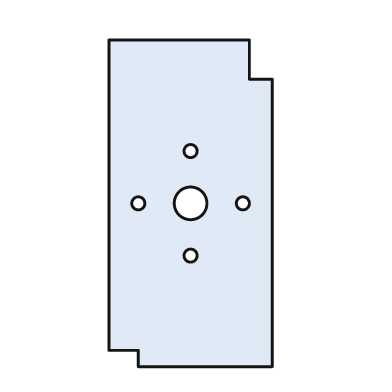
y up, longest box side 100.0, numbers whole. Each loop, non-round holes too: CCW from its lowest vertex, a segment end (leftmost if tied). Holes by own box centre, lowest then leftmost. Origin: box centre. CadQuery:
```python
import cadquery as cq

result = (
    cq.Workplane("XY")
    .moveTo(-16.0, -50.0)
    .lineTo(25.0, -50.0)
    .lineTo(25.0, 38.0)
    .lineTo(18.0, 38.0)
    .lineTo(18.0, 50.0)
    .lineTo(-25.0, 50.0)
    .lineTo(-25.0, -45.0)
    .lineTo(-16.0, -45.0)
    .close()
    .moveTo(0.0, -16.0)
    .circle(2.0)
    .moveTo(-16.0, 0.0)
    .circle(2.0)
    .moveTo(0.0, 0.0)
    .circle(5.0)
    .moveTo(16.0, 0.0)
    .circle(2.0)
    .moveTo(0.0, 16.0)
    .circle(2.0)
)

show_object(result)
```